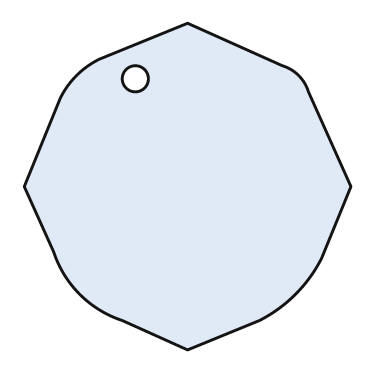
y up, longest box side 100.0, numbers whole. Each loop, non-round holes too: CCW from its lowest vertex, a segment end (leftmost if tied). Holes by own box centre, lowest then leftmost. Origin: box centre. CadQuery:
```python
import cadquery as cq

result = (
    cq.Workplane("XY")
    .moveTo(0.0, -50.0)
    .lineTo(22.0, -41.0)
    .threePointArc((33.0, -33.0), (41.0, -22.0))
    .lineTo(50.0, 0.0)
    .lineTo(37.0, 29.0)
    .threePointArc((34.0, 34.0), (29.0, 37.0))
    .lineTo(0.0, 50.0)
    .lineTo(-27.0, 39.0)
    .threePointArc((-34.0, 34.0), (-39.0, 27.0))
    .lineTo(-50.0, 0.0)
    .lineTo(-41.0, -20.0)
    .threePointArc((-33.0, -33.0), (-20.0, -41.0))
    .close()
    .moveTo(-16.0, 33.0)
    .circle(4.0)
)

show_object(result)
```